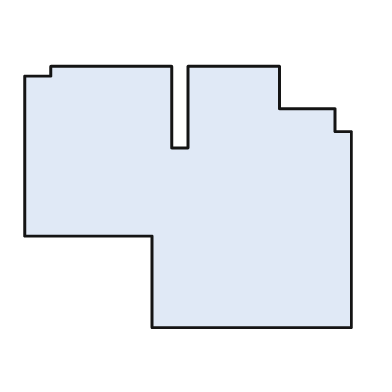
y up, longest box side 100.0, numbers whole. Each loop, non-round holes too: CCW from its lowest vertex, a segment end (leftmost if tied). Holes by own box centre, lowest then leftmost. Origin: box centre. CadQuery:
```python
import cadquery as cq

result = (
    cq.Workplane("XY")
    .moveTo(-11.0, -40.0)
    .lineTo(50.0, -40.0)
    .lineTo(50.0, 20.0)
    .lineTo(45.0, 20.0)
    .lineTo(45.0, 27.0)
    .lineTo(28.0, 27.0)
    .lineTo(28.0, 40.0)
    .lineTo(0.0, 40.0)
    .lineTo(0.0, 15.0)
    .lineTo(-5.0, 15.0)
    .lineTo(-5.0, 40.0)
    .lineTo(-42.0, 40.0)
    .lineTo(-42.0, 37.0)
    .lineTo(-50.0, 37.0)
    .lineTo(-50.0, -12.0)
    .lineTo(-11.0, -12.0)
    .close()
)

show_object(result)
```